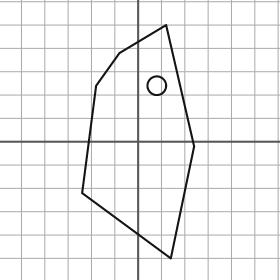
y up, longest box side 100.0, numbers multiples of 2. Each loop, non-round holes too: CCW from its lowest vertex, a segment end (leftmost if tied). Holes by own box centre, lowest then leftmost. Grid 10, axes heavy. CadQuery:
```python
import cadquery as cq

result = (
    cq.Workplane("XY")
    .moveTo(14.0, -50.0)
    .lineTo(24.0, -2.0)
    .lineTo(12.0, 50.0)
    .lineTo(-8.0, 38.0)
    .lineTo(-18.0, 24.0)
    .lineTo(-24.0, -22.0)
    .close()
    .moveTo(8.0, 24.0)
    .circle(4.0)
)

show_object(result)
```